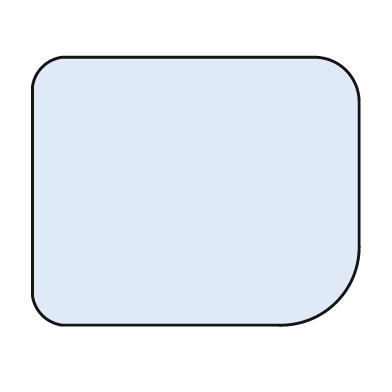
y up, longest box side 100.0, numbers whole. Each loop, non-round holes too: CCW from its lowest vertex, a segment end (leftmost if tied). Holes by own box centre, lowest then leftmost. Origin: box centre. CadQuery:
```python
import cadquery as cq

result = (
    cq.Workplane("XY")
    .moveTo(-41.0, -41.0)
    .lineTo(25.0, -41.0)
    .threePointArc((43.0, -34.0), (50.0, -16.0))
    .lineTo(50.0, 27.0)
    .threePointArc((46.0, 37.0), (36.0, 41.0))
    .lineTo(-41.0, 41.0)
    .threePointArc((-47.0, 38.0), (-50.0, 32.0))
    .lineTo(-50.0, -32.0)
    .threePointArc((-47.0, -38.0), (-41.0, -41.0))
    .close()
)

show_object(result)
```